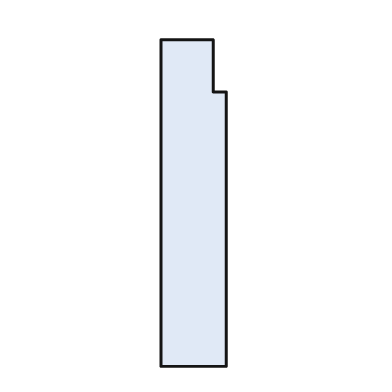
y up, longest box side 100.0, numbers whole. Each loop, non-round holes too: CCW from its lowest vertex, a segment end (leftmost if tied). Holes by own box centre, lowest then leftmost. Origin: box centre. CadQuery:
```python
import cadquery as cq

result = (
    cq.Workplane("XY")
    .moveTo(-10.0, -50.0)
    .lineTo(10.0, -50.0)
    .lineTo(10.0, 34.0)
    .lineTo(6.0, 34.0)
    .lineTo(6.0, 50.0)
    .lineTo(-10.0, 50.0)
    .close()
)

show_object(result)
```